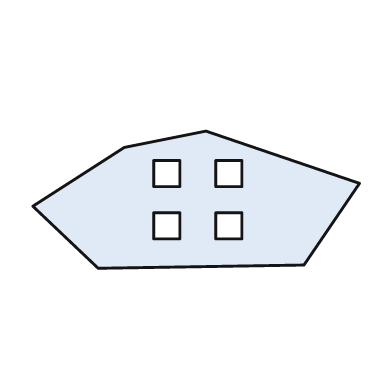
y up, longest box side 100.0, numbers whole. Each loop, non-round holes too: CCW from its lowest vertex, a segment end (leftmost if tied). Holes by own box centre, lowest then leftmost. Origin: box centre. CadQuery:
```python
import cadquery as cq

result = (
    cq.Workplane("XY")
    .moveTo(-30.0, -21.0)
    .lineTo(33.0, -20.0)
    .lineTo(50.0, 5.0)
    .lineTo(3.0, 21.0)
    .lineTo(-22.0, 16.0)
    .lineTo(-50.0, -2.0)
    .close()
    .moveTo(-13.0, -12.0)
    .lineTo(-5.0, -12.0)
    .lineTo(-5.0, -4.0)
    .lineTo(-13.0, -4.0)
    .close()
    .moveTo(6.0, -12.0)
    .lineTo(14.0, -12.0)
    .lineTo(14.0, -4.0)
    .lineTo(6.0, -4.0)
    .close()
    .moveTo(-13.0, 4.0)
    .lineTo(-5.0, 4.0)
    .lineTo(-5.0, 12.0)
    .lineTo(-13.0, 12.0)
    .close()
    .moveTo(6.0, 4.0)
    .lineTo(14.0, 4.0)
    .lineTo(14.0, 12.0)
    .lineTo(6.0, 12.0)
    .close()
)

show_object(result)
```